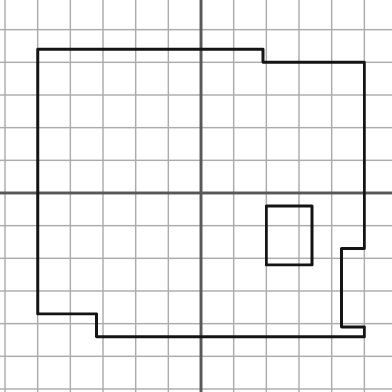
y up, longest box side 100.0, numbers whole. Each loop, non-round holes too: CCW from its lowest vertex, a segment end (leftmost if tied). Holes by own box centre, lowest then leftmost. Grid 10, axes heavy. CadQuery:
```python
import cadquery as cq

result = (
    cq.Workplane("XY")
    .moveTo(-32.0, -44.0)
    .lineTo(50.0, -44.0)
    .lineTo(50.0, -41.0)
    .lineTo(43.0, -41.0)
    .lineTo(43.0, -17.0)
    .lineTo(50.0, -17.0)
    .lineTo(50.0, 40.0)
    .lineTo(19.0, 40.0)
    .lineTo(19.0, 44.0)
    .lineTo(-50.0, 44.0)
    .lineTo(-50.0, -37.0)
    .lineTo(-32.0, -37.0)
    .close()
    .moveTo(20.0, -22.0)
    .lineTo(34.0, -22.0)
    .lineTo(34.0, -4.0)
    .lineTo(20.0, -4.0)
    .close()
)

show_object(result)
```